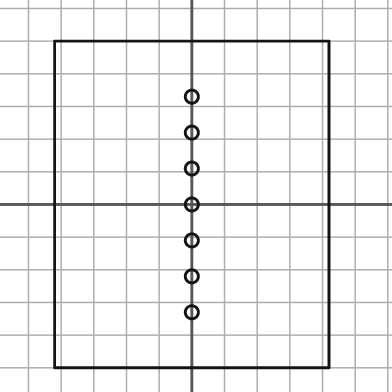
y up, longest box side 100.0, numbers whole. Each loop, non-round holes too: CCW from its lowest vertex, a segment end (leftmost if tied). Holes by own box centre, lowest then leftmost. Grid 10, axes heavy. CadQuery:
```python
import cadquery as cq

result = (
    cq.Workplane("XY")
    .moveTo(-42.0, -50.0)
    .lineTo(42.0, -50.0)
    .lineTo(42.0, 50.0)
    .lineTo(-42.0, 50.0)
    .close()
    .moveTo(0.0, -33.0)
    .circle(2.0)
    .moveTo(0.0, -22.0)
    .circle(2.0)
    .moveTo(0.0, -11.0)
    .circle(2.0)
    .moveTo(0.0, 0.0)
    .circle(2.0)
    .moveTo(0.0, 11.0)
    .circle(2.0)
    .moveTo(0.0, 22.0)
    .circle(2.0)
    .moveTo(0.0, 33.0)
    .circle(2.0)
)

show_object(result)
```